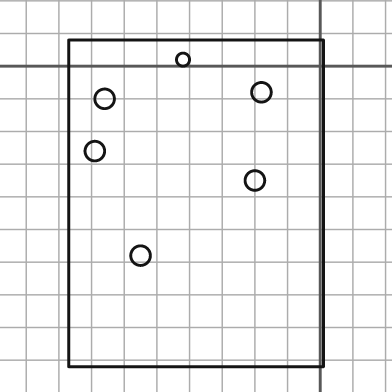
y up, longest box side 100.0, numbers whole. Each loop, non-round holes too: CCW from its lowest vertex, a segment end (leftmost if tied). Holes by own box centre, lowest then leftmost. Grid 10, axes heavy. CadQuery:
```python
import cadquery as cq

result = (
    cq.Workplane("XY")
    .moveTo(-77.0, -92.0)
    .lineTo(1.0, -92.0)
    .lineTo(1.0, 8.0)
    .lineTo(-77.0, 8.0)
    .close()
    .moveTo(-55.0, -58.0)
    .circle(3.0)
    .moveTo(-20.0, -35.0)
    .circle(3.0)
    .moveTo(-69.0, -26.0)
    .circle(3.0)
    .moveTo(-66.0, -10.0)
    .circle(3.0)
    .moveTo(-18.0, -8.0)
    .circle(3.0)
    .moveTo(-42.0, 2.0)
    .circle(2.0)
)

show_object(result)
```